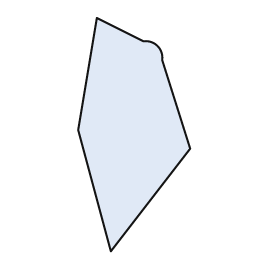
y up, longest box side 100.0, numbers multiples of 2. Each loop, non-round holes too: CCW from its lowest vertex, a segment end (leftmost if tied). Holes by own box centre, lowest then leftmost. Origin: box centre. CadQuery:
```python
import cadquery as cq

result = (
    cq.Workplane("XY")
    .moveTo(-10.0, -50.0)
    .lineTo(24.0, -6.0)
    .lineTo(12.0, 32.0)
    .threePointArc((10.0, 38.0), (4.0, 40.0))
    .lineTo(-16.0, 50.0)
    .lineTo(-24.0, 2.0)
    .close()
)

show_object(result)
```